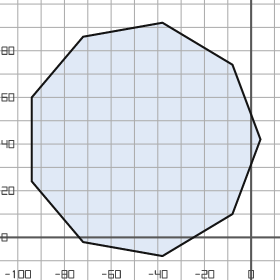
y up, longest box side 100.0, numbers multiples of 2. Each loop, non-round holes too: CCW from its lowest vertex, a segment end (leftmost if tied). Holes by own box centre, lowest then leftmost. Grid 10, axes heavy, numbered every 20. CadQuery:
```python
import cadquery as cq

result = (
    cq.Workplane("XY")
    .moveTo(-38.0, -8.0)
    .lineTo(-8.0, 10.0)
    .lineTo(4.0, 42.0)
    .lineTo(-8.0, 74.0)
    .lineTo(-38.0, 92.0)
    .lineTo(-72.0, 86.0)
    .lineTo(-94.0, 60.0)
    .lineTo(-94.0, 24.0)
    .lineTo(-72.0, -2.0)
    .close()
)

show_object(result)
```